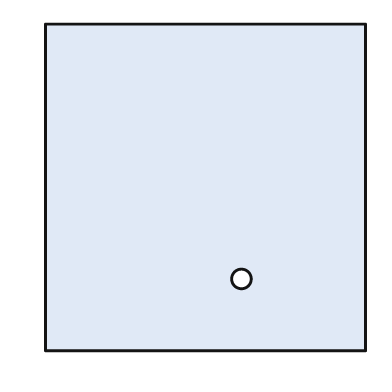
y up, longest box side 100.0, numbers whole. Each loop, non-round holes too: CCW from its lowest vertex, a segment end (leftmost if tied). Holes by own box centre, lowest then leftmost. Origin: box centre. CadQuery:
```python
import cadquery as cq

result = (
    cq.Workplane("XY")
    .moveTo(-49.0, -50.0)
    .lineTo(49.0, -50.0)
    .lineTo(49.0, 50.0)
    .lineTo(-49.0, 50.0)
    .close()
    .moveTo(11.0, -28.0)
    .circle(3.0)
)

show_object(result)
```